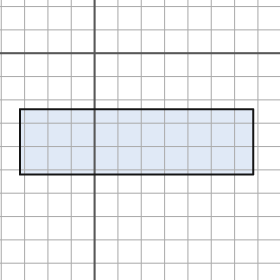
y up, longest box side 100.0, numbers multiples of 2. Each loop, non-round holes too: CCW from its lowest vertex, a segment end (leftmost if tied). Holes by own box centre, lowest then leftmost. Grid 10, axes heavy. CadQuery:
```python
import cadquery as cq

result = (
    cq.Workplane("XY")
    .moveTo(-32.0, -52.0)
    .lineTo(68.0, -52.0)
    .lineTo(68.0, -24.0)
    .lineTo(-32.0, -24.0)
    .close()
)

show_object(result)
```